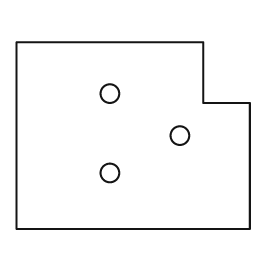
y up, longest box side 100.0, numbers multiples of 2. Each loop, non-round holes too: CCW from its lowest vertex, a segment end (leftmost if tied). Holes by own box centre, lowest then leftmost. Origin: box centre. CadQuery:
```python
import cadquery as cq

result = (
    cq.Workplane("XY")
    .moveTo(-50.0, -40.0)
    .lineTo(50.0, -40.0)
    .lineTo(50.0, 14.0)
    .lineTo(30.0, 14.0)
    .lineTo(30.0, 40.0)
    .lineTo(-50.0, 40.0)
    .close()
    .moveTo(-10.0, -16.0)
    .circle(4.0)
    .moveTo(20.0, 0.0)
    .circle(4.0)
    .moveTo(-10.0, 18.0)
    .circle(4.0)
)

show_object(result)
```